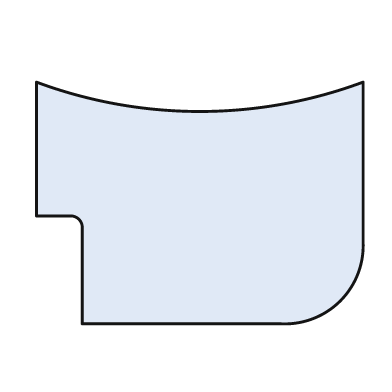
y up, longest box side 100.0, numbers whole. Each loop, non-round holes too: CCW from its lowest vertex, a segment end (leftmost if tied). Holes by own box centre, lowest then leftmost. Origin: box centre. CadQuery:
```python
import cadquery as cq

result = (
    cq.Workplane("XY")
    .moveTo(-36.0, -37.0)
    .lineTo(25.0, -37.0)
    .threePointArc((43.0, -30.0), (50.0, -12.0))
    .lineTo(50.0, 37.0)
    .threePointArc((0.0, 28.0), (-50.0, 37.0))
    .lineTo(-50.0, -4.0)
    .lineTo(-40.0, -4.0)
    .threePointArc((-37.0, -5.0), (-36.0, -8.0))
    .close()
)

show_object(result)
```